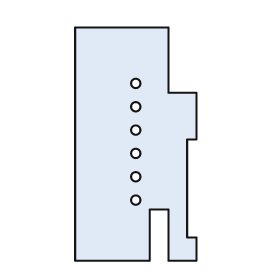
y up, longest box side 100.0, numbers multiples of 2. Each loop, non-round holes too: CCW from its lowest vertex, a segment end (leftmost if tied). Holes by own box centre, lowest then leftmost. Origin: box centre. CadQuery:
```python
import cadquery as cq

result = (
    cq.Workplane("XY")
    .moveTo(-26.0, -50.0)
    .lineTo(6.0, -50.0)
    .lineTo(6.0, -28.0)
    .lineTo(14.0, -28.0)
    .lineTo(14.0, -50.0)
    .lineTo(26.0, -50.0)
    .lineTo(26.0, -40.0)
    .lineTo(22.0, -40.0)
    .lineTo(22.0, 2.0)
    .lineTo(26.0, 2.0)
    .lineTo(26.0, 22.0)
    .lineTo(14.0, 22.0)
    .lineTo(14.0, 50.0)
    .lineTo(-26.0, 50.0)
    .close()
    .moveTo(0.0, -24.0)
    .circle(2.0)
    .moveTo(0.0, -14.0)
    .circle(2.0)
    .moveTo(0.0, -4.0)
    .circle(2.0)
    .moveTo(0.0, 6.0)
    .circle(2.0)
    .moveTo(0.0, 16.0)
    .circle(2.0)
    .moveTo(0.0, 26.0)
    .circle(2.0)
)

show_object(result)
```